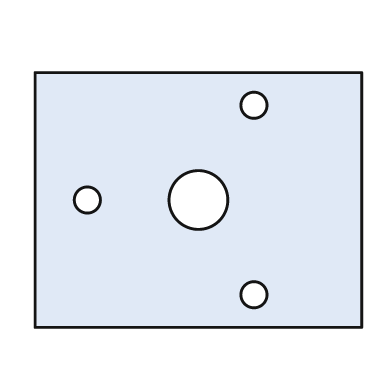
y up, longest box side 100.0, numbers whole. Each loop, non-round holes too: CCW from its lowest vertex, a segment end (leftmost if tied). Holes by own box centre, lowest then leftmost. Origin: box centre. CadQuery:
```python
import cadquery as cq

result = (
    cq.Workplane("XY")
    .moveTo(-50.0, -39.0)
    .lineTo(50.0, -39.0)
    .lineTo(50.0, 39.0)
    .lineTo(-50.0, 39.0)
    .close()
    .moveTo(17.0, -29.0)
    .circle(4.0)
    .moveTo(-34.0, 0.0)
    .circle(4.0)
    .moveTo(0.0, 0.0)
    .circle(9.0)
    .moveTo(17.0, 29.0)
    .circle(4.0)
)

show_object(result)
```